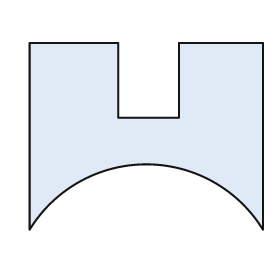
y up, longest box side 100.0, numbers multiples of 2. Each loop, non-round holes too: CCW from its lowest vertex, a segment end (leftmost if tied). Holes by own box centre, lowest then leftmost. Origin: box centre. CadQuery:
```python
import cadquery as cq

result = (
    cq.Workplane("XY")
    .moveTo(-50.0, -40.0)
    .threePointArc((0.0, -12.0), (50.0, -40.0))
    .lineTo(50.0, 40.0)
    .lineTo(14.0, 40.0)
    .lineTo(14.0, 8.0)
    .lineTo(-12.0, 8.0)
    .lineTo(-12.0, 40.0)
    .lineTo(-50.0, 40.0)
    .close()
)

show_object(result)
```